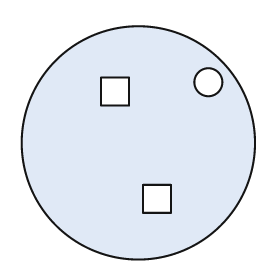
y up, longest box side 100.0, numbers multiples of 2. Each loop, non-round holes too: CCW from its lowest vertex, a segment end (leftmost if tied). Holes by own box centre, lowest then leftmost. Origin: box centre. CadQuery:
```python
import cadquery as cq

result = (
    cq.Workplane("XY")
    .moveTo(0.0, 0.0)
    .circle(50.0)
    .moveTo(2.0, -30.0)
    .lineTo(14.0, -30.0)
    .lineTo(14.0, -18.0)
    .lineTo(2.0, -18.0)
    .close()
    .moveTo(-16.0, 16.0)
    .lineTo(-4.0, 16.0)
    .lineTo(-4.0, 28.0)
    .lineTo(-16.0, 28.0)
    .close()
    .moveTo(30.0, 26.0)
    .circle(6.0)
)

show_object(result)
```